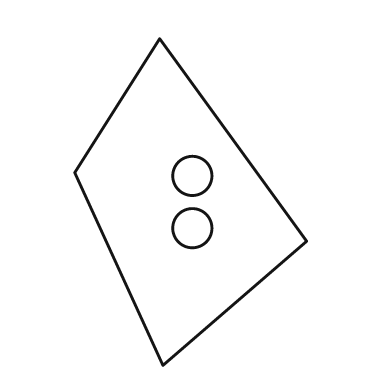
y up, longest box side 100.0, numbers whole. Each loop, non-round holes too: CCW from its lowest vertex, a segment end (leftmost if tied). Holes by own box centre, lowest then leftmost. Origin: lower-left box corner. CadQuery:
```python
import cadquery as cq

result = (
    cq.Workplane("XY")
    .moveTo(27.0, 0.0)
    .lineTo(71.0, 38.0)
    .lineTo(26.0, 100.0)
    .lineTo(0.0, 59.0)
    .close()
    .moveTo(36.0, 42.0)
    .circle(6.0)
    .moveTo(36.0, 58.0)
    .circle(6.0)
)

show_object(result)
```